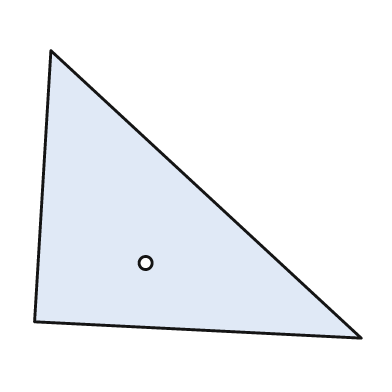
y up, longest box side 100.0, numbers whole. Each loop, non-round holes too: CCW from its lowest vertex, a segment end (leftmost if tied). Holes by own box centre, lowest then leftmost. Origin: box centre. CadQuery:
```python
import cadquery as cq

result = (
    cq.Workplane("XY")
    .moveTo(50.0, -44.0)
    .lineTo(-45.0, 44.0)
    .lineTo(-50.0, -39.0)
    .close()
    .moveTo(-16.0, -21.0)
    .circle(2.0)
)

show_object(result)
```